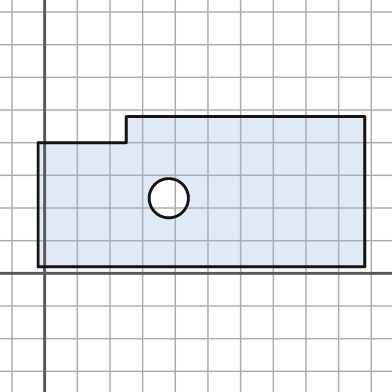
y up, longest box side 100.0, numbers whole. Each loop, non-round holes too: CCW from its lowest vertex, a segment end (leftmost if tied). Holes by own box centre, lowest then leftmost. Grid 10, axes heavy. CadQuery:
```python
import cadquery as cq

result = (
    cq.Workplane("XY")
    .moveTo(-2.0, 2.0)
    .lineTo(98.0, 2.0)
    .lineTo(98.0, 48.0)
    .lineTo(25.0, 48.0)
    .lineTo(25.0, 40.0)
    .lineTo(-2.0, 40.0)
    .close()
    .moveTo(38.0, 23.0)
    .circle(6.0)
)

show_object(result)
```